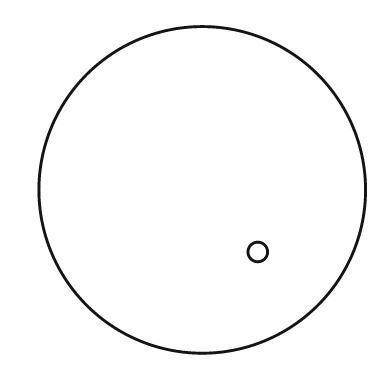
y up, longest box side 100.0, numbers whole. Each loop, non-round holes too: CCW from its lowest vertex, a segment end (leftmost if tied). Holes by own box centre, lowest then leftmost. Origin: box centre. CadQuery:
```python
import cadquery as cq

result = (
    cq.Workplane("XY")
    .moveTo(0.0, 0.0)
    .circle(50.0)
    .moveTo(17.0, -19.0)
    .circle(3.0)
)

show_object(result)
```